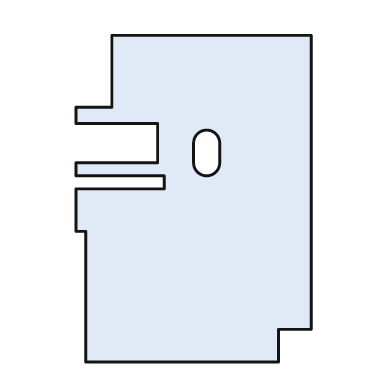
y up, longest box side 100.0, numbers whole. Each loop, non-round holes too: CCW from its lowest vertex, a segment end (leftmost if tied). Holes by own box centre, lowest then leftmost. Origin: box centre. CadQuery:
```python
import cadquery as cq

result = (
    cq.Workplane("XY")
    .moveTo(-33.0, -50.0)
    .lineTo(26.0, -50.0)
    .lineTo(26.0, -40.0)
    .lineTo(36.0, -40.0)
    .lineTo(36.0, 50.0)
    .lineTo(-25.0, 50.0)
    .lineTo(-25.0, 28.0)
    .lineTo(-36.0, 28.0)
    .lineTo(-36.0, 23.0)
    .lineTo(-11.0, 23.0)
    .lineTo(-11.0, 11.0)
    .lineTo(-36.0, 11.0)
    .lineTo(-36.0, 7.0)
    .lineTo(-9.0, 7.0)
    .lineTo(-9.0, 3.0)
    .lineTo(-36.0, 3.0)
    .lineTo(-36.0, -10.0)
    .lineTo(-33.0, -10.0)
    .close()
    .moveTo(0.0, 11.0)
    .threePointArc((4.0, 7.0), (8.0, 11.0))
    .lineTo(8.0, 17.0)
    .threePointArc((4.0, 21.0), (0.0, 17.0))
    .close()
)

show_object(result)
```